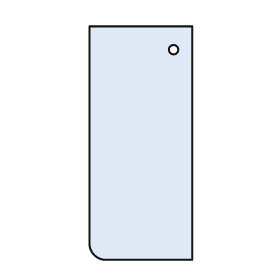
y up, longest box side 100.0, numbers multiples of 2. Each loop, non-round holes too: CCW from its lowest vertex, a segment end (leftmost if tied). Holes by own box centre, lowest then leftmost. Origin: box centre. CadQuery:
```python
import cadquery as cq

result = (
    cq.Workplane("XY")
    .moveTo(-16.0, -50.0)
    .lineTo(22.0, -50.0)
    .lineTo(22.0, 50.0)
    .lineTo(-22.0, 50.0)
    .lineTo(-22.0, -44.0)
    .threePointArc((-20.0, -48.0), (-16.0, -50.0))
    .close()
    .moveTo(14.0, 40.0)
    .circle(2.0)
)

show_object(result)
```